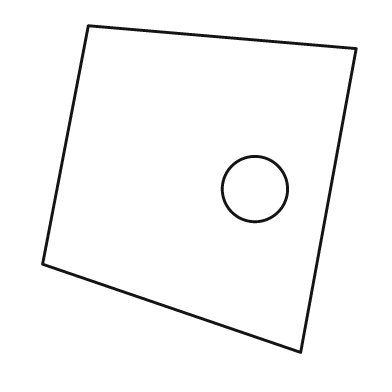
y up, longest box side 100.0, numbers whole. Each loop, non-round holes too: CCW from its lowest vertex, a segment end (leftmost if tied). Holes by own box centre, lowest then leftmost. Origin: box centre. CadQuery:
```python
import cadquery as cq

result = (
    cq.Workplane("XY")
    .moveTo(31.0, -50.0)
    .lineTo(48.0, 43.0)
    .lineTo(-34.0, 50.0)
    .lineTo(-48.0, -23.0)
    .close()
    .moveTo(17.0, 0.0)
    .circle(10.0)
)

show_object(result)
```